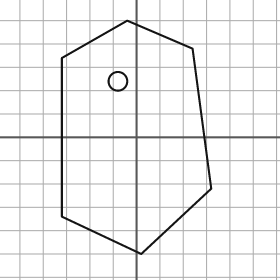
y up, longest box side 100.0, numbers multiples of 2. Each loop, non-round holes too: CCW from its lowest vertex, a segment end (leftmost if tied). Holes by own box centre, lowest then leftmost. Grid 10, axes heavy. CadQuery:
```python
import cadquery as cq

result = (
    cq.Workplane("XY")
    .moveTo(2.0, -50.0)
    .lineTo(32.0, -22.0)
    .lineTo(24.0, 38.0)
    .lineTo(-4.0, 50.0)
    .lineTo(-32.0, 34.0)
    .lineTo(-32.0, -34.0)
    .close()
    .moveTo(-8.0, 24.0)
    .circle(4.0)
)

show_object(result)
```